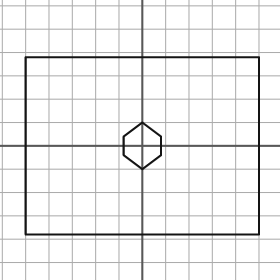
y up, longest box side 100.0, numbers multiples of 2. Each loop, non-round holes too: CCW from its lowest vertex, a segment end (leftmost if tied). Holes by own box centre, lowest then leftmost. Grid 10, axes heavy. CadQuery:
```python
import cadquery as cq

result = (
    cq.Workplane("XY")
    .moveTo(-50.0, -38.0)
    .lineTo(50.0, -38.0)
    .lineTo(50.0, 38.0)
    .lineTo(-50.0, 38.0)
    .close()
    .moveTo(0.0, -10.0)
    .lineTo(8.0, -4.0)
    .lineTo(8.0, 4.0)
    .lineTo(0.0, 10.0)
    .lineTo(-8.0, 4.0)
    .lineTo(-8.0, -4.0)
    .close()
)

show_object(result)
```